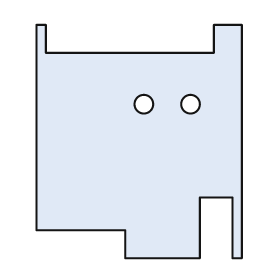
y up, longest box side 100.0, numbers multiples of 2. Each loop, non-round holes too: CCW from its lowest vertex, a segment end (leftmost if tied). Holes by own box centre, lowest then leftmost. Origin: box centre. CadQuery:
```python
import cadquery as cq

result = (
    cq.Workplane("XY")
    .moveTo(-6.0, -50.0)
    .lineTo(26.0, -50.0)
    .lineTo(26.0, -24.0)
    .lineTo(40.0, -24.0)
    .lineTo(40.0, -50.0)
    .lineTo(44.0, -50.0)
    .lineTo(44.0, 50.0)
    .lineTo(32.0, 50.0)
    .lineTo(32.0, 38.0)
    .lineTo(-40.0, 38.0)
    .lineTo(-40.0, 50.0)
    .lineTo(-44.0, 50.0)
    .lineTo(-44.0, -38.0)
    .lineTo(-6.0, -38.0)
    .close()
    .moveTo(2.0, 16.0)
    .circle(4.0)
    .moveTo(22.0, 16.0)
    .circle(4.0)
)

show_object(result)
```